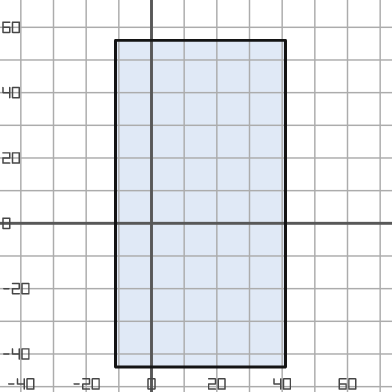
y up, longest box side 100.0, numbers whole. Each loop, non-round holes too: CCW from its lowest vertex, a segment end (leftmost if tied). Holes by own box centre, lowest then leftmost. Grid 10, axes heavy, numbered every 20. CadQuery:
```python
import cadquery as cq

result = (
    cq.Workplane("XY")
    .moveTo(-11.0, -44.0)
    .lineTo(41.0, -44.0)
    .lineTo(41.0, 56.0)
    .lineTo(-11.0, 56.0)
    .close()
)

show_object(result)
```